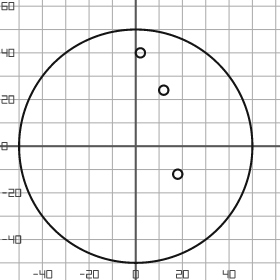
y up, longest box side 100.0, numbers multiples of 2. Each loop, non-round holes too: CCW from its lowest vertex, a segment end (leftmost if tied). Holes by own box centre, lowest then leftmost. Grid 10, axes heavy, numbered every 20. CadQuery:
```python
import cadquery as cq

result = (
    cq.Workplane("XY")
    .moveTo(0.0, 0.0)
    .circle(50.0)
    .moveTo(18.0, -12.0)
    .circle(2.0)
    .moveTo(12.0, 24.0)
    .circle(2.0)
    .moveTo(2.0, 40.0)
    .circle(2.0)
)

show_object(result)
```